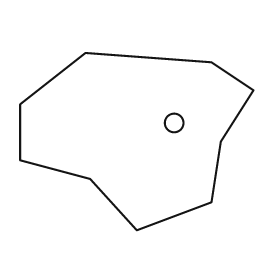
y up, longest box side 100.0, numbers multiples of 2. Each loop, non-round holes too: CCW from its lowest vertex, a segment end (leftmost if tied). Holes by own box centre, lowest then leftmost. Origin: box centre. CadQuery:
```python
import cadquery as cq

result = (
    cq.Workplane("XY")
    .moveTo(0.0, -38.0)
    .lineTo(32.0, -26.0)
    .lineTo(36.0, 0.0)
    .lineTo(50.0, 22.0)
    .lineTo(32.0, 34.0)
    .lineTo(-22.0, 38.0)
    .lineTo(-50.0, 16.0)
    .lineTo(-50.0, -8.0)
    .lineTo(-20.0, -16.0)
    .close()
    .moveTo(16.0, 8.0)
    .circle(4.0)
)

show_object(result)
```